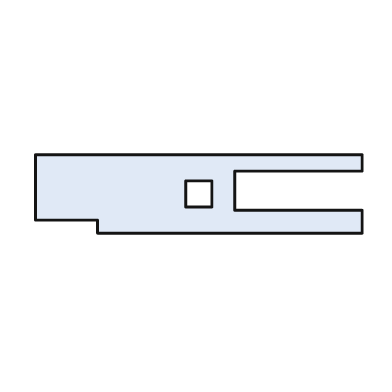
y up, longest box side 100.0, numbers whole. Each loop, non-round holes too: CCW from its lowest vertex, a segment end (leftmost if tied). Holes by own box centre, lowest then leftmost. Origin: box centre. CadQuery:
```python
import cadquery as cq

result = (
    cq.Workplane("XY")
    .moveTo(-31.0, -12.0)
    .lineTo(50.0, -12.0)
    .lineTo(50.0, -5.0)
    .lineTo(11.0, -5.0)
    .lineTo(11.0, 7.0)
    .lineTo(50.0, 7.0)
    .lineTo(50.0, 12.0)
    .lineTo(-50.0, 12.0)
    .lineTo(-50.0, -8.0)
    .lineTo(-31.0, -8.0)
    .close()
    .moveTo(-4.0, -4.0)
    .lineTo(4.0, -4.0)
    .lineTo(4.0, 4.0)
    .lineTo(-4.0, 4.0)
    .close()
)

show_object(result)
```